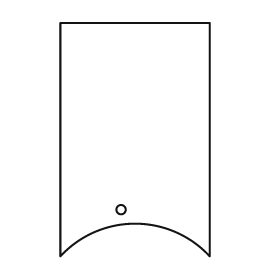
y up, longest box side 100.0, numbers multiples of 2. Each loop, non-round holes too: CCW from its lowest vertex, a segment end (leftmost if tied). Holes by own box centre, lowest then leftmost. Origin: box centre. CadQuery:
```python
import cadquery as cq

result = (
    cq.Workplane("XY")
    .moveTo(-32.0, -50.0)
    .threePointArc((0.0, -36.0), (32.0, -50.0))
    .lineTo(32.0, 50.0)
    .lineTo(-32.0, 50.0)
    .close()
    .moveTo(-6.0, -30.0)
    .circle(2.0)
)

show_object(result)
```